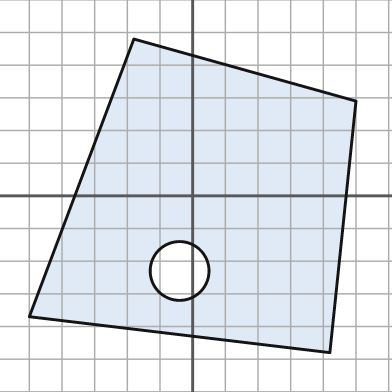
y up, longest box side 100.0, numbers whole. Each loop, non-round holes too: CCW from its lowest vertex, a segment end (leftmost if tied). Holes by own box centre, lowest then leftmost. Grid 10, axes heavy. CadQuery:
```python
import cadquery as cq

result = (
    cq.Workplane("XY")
    .moveTo(42.0, -48.0)
    .lineTo(50.0, 29.0)
    .lineTo(-18.0, 48.0)
    .lineTo(-50.0, -37.0)
    .close()
    .moveTo(-4.0, -23.0)
    .circle(9.0)
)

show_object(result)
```